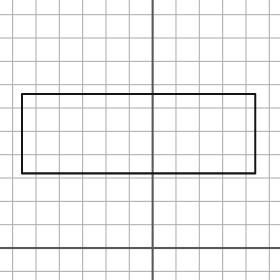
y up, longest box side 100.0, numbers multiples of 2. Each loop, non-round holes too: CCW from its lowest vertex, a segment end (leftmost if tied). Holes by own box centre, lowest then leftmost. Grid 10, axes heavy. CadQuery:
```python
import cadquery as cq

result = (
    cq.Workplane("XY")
    .moveTo(-56.0, 32.0)
    .lineTo(44.0, 32.0)
    .lineTo(44.0, 66.0)
    .lineTo(-56.0, 66.0)
    .close()
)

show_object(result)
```